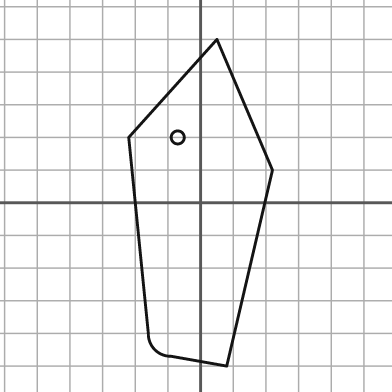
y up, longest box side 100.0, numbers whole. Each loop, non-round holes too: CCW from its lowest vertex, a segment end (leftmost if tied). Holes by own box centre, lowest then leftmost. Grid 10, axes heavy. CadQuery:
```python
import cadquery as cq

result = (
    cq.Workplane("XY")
    .moveTo(8.0, -50.0)
    .lineTo(22.0, 10.0)
    .lineTo(5.0, 50.0)
    .lineTo(-22.0, 20.0)
    .lineTo(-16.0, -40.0)
    .threePointArc((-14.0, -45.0), (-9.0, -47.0))
    .close()
    .moveTo(-7.0, 20.0)
    .circle(2.0)
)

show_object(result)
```